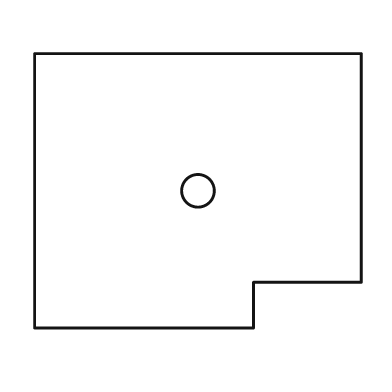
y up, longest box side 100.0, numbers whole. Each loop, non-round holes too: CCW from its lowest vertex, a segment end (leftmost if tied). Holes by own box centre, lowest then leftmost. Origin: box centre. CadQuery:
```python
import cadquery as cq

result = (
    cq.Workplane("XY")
    .moveTo(-50.0, -42.0)
    .lineTo(17.0, -42.0)
    .lineTo(17.0, -28.0)
    .lineTo(50.0, -28.0)
    .lineTo(50.0, 42.0)
    .lineTo(-50.0, 42.0)
    .close()
    .moveTo(0.0, 0.0)
    .circle(5.0)
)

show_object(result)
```